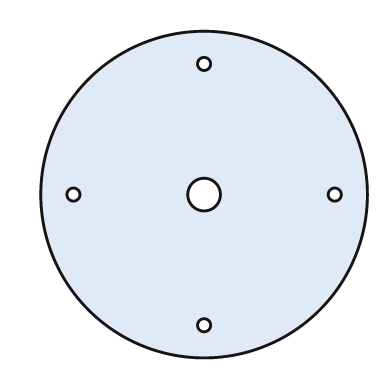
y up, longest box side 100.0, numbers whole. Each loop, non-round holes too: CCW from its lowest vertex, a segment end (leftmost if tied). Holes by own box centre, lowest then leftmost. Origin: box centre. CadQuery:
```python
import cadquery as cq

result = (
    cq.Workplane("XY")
    .moveTo(0.0, 0.0)
    .circle(50.0)
    .moveTo(0.0, -40.0)
    .circle(2.0)
    .moveTo(-40.0, 0.0)
    .circle(2.0)
    .moveTo(0.0, 0.0)
    .circle(5.0)
    .moveTo(40.0, 0.0)
    .circle(2.0)
    .moveTo(0.0, 40.0)
    .circle(2.0)
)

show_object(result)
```